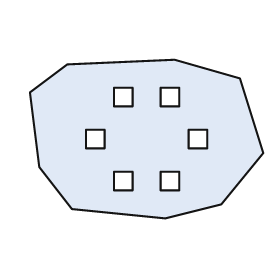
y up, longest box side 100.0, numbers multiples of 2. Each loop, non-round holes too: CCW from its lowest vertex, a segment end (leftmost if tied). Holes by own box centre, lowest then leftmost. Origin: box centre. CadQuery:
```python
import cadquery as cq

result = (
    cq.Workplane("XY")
    .moveTo(8.0, -34.0)
    .lineTo(32.0, -28.0)
    .lineTo(50.0, -6.0)
    .lineTo(40.0, 26.0)
    .lineTo(12.0, 34.0)
    .lineTo(-34.0, 32.0)
    .lineTo(-50.0, 20.0)
    .lineTo(-46.0, -12.0)
    .lineTo(-32.0, -30.0)
    .close()
    .moveTo(-14.0, -22.0)
    .lineTo(-6.0, -22.0)
    .lineTo(-6.0, -14.0)
    .lineTo(-14.0, -14.0)
    .close()
    .moveTo(6.0, -22.0)
    .lineTo(14.0, -22.0)
    .lineTo(14.0, -14.0)
    .lineTo(6.0, -14.0)
    .close()
    .moveTo(-26.0, -4.0)
    .lineTo(-18.0, -4.0)
    .lineTo(-18.0, 4.0)
    .lineTo(-26.0, 4.0)
    .close()
    .moveTo(18.0, -4.0)
    .lineTo(26.0, -4.0)
    .lineTo(26.0, 4.0)
    .lineTo(18.0, 4.0)
    .close()
    .moveTo(-14.0, 14.0)
    .lineTo(-6.0, 14.0)
    .lineTo(-6.0, 22.0)
    .lineTo(-14.0, 22.0)
    .close()
    .moveTo(6.0, 14.0)
    .lineTo(14.0, 14.0)
    .lineTo(14.0, 22.0)
    .lineTo(6.0, 22.0)
    .close()
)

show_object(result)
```